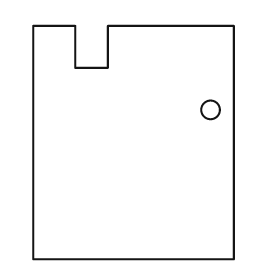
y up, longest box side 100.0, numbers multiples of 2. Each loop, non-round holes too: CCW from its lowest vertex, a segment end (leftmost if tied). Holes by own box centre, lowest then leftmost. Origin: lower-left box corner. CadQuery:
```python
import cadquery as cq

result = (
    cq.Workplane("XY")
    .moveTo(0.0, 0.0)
    .lineTo(86.0, 0.0)
    .lineTo(86.0, 100.0)
    .lineTo(32.0, 100.0)
    .lineTo(32.0, 82.0)
    .lineTo(18.0, 82.0)
    .lineTo(18.0, 100.0)
    .lineTo(0.0, 100.0)
    .close()
    .moveTo(76.0, 64.0)
    .circle(4.0)
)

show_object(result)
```